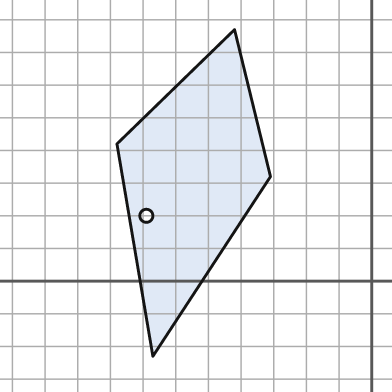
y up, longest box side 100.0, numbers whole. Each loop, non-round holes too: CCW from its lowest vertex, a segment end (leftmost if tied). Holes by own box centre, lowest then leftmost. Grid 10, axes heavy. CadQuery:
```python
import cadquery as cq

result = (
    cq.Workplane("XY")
    .moveTo(-67.0, -23.0)
    .lineTo(-31.0, 32.0)
    .lineTo(-42.0, 77.0)
    .lineTo(-78.0, 42.0)
    .close()
    .moveTo(-69.0, 20.0)
    .circle(2.0)
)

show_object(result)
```